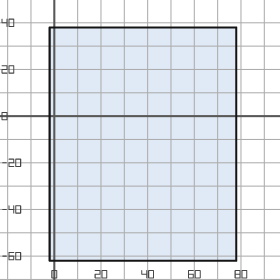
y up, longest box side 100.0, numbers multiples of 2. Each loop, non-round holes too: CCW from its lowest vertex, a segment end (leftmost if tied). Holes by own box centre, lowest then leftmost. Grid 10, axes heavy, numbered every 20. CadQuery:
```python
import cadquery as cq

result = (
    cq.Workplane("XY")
    .moveTo(-2.0, -62.0)
    .lineTo(78.0, -62.0)
    .lineTo(78.0, 38.0)
    .lineTo(-2.0, 38.0)
    .close()
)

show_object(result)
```